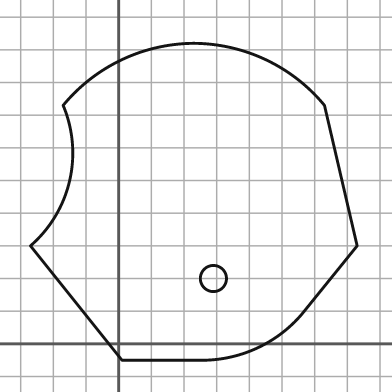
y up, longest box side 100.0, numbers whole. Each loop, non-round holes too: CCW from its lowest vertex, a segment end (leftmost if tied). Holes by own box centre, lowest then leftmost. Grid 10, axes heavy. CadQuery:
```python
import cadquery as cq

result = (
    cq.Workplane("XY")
    .moveTo(1.0, -5.0)
    .lineTo(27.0, -5.0)
    .threePointArc((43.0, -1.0), (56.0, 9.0))
    .lineTo(73.0, 30.0)
    .lineTo(63.0, 73.0)
    .threePointArc((45.0, 87.0), (23.0, 92.0))
    .threePointArc((1.0, 87.0), (-17.0, 73.0))
    .threePointArc((-15.0, 50.0), (-27.0, 30.0))
    .close()
    .moveTo(29.0, 20.0)
    .circle(4.0)
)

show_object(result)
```